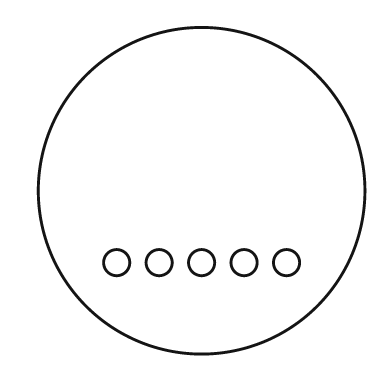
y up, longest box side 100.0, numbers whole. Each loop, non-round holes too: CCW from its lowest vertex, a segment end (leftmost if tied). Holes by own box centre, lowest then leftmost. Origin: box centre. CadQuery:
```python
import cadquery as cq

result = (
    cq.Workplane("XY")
    .moveTo(0.0, 0.0)
    .circle(50.0)
    .moveTo(-26.0, -22.0)
    .circle(4.0)
    .moveTo(-13.0, -22.0)
    .circle(4.0)
    .moveTo(0.0, -22.0)
    .circle(4.0)
    .moveTo(13.0, -22.0)
    .circle(4.0)
    .moveTo(26.0, -22.0)
    .circle(4.0)
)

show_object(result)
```